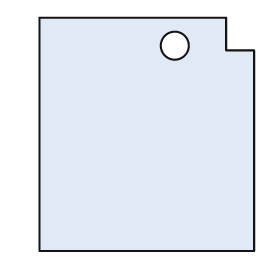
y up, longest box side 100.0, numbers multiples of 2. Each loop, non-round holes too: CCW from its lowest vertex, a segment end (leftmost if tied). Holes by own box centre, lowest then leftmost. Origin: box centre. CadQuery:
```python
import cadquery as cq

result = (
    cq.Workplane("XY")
    .moveTo(-46.0, -50.0)
    .lineTo(46.0, -50.0)
    .lineTo(46.0, 36.0)
    .lineTo(34.0, 36.0)
    .lineTo(34.0, 50.0)
    .lineTo(-46.0, 50.0)
    .close()
    .moveTo(12.0, 38.0)
    .circle(6.0)
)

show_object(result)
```